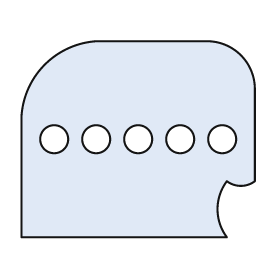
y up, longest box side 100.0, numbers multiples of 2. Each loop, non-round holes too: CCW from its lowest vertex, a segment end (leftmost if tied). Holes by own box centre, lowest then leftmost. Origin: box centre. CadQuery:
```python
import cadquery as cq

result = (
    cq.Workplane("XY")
    .moveTo(-50.0, -42.0)
    .lineTo(38.0, -42.0)
    .threePointArc((34.0, -30.0), (38.0, -18.0))
    .threePointArc((44.0, -20.0), (50.0, -18.0))
    .lineTo(50.0, 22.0)
    .threePointArc((44.0, 36.0), (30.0, 42.0))
    .lineTo(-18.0, 42.0)
    .threePointArc((-40.0, 32.0), (-50.0, 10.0))
    .close()
    .moveTo(-36.0, 0.0)
    .circle(6.0)
    .moveTo(-18.0, 0.0)
    .circle(6.0)
    .moveTo(0.0, 0.0)
    .circle(6.0)
    .moveTo(18.0, 0.0)
    .circle(6.0)
    .moveTo(36.0, 0.0)
    .circle(6.0)
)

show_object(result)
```